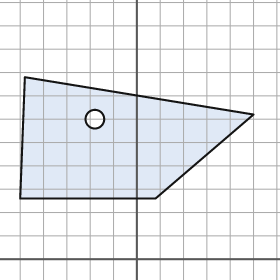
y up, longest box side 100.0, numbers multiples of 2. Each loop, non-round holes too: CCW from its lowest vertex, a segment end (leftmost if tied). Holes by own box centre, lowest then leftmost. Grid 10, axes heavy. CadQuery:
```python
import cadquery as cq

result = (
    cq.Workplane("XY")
    .moveTo(-50.0, 26.0)
    .lineTo(8.0, 26.0)
    .lineTo(50.0, 62.0)
    .lineTo(-48.0, 78.0)
    .close()
    .moveTo(-18.0, 60.0)
    .circle(4.0)
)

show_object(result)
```